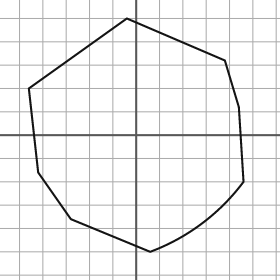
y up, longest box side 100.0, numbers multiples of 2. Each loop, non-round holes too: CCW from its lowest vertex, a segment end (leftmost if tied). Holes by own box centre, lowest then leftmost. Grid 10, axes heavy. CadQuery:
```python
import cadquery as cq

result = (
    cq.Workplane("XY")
    .moveTo(6.0, -50.0)
    .threePointArc((28.0, -38.0), (46.0, -20.0))
    .lineTo(44.0, 12.0)
    .lineTo(38.0, 32.0)
    .lineTo(-4.0, 50.0)
    .lineTo(-46.0, 20.0)
    .lineTo(-42.0, -16.0)
    .lineTo(-28.0, -36.0)
    .close()
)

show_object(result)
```